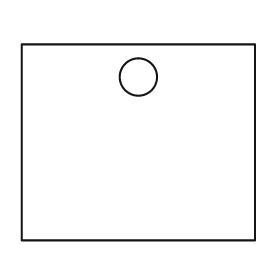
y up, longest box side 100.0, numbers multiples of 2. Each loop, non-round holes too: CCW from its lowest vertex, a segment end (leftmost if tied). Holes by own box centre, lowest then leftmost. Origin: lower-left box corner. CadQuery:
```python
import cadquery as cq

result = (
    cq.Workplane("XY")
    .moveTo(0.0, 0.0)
    .lineTo(100.0, 0.0)
    .lineTo(100.0, 84.0)
    .lineTo(0.0, 84.0)
    .close()
    .moveTo(50.0, 70.0)
    .circle(8.0)
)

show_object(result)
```